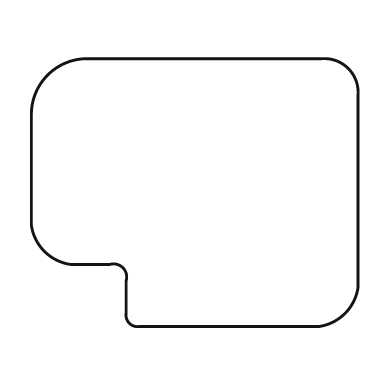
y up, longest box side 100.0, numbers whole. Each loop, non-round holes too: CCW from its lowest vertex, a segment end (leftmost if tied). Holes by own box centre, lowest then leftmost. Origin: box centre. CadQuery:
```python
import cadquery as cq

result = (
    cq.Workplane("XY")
    .moveTo(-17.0, -41.0)
    .lineTo(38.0, -41.0)
    .threePointArc((46.0, -37.0), (50.0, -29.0))
    .lineTo(50.0, 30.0)
    .threePointArc((47.0, 38.0), (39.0, 41.0))
    .lineTo(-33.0, 41.0)
    .threePointArc((-45.0, 36.0), (-50.0, 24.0))
    .lineTo(-50.0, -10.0)
    .threePointArc((-46.0, -18.0), (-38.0, -22.0))
    .lineTo(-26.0, -22.0)
    .threePointArc((-22.0, -23.0), (-21.0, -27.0))
    .lineTo(-21.0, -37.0)
    .threePointArc((-20.0, -40.0), (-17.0, -41.0))
    .close()
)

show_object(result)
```